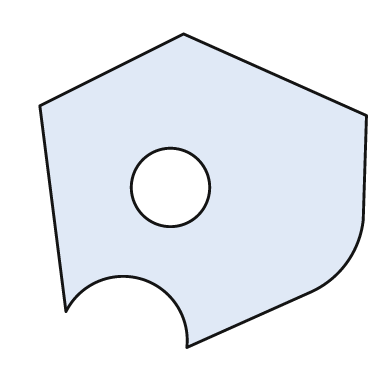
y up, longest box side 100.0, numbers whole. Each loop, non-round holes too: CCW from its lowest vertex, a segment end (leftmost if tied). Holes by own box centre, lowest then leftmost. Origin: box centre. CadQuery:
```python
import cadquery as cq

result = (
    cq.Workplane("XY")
    .moveTo(-5.0, -48.0)
    .lineTo(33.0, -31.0)
    .threePointArc((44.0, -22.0), (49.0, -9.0))
    .lineTo(50.0, 23.0)
    .lineTo(-6.0, 48.0)
    .lineTo(-50.0, 26.0)
    .lineTo(-42.0, -37.0)
    .threePointArc((-19.0, -27.0), (-5.0, -48.0))
    .close()
    .moveTo(-10.0, 1.0)
    .circle(12.0)
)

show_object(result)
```